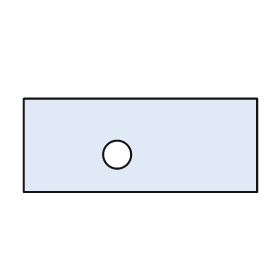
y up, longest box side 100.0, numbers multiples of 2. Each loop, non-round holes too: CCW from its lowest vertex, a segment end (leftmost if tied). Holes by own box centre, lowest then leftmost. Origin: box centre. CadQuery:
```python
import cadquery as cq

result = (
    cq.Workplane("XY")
    .moveTo(-50.0, -20.0)
    .lineTo(50.0, -20.0)
    .lineTo(50.0, 20.0)
    .lineTo(-50.0, 20.0)
    .close()
    .moveTo(-10.0, -4.0)
    .circle(6.0)
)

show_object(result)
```